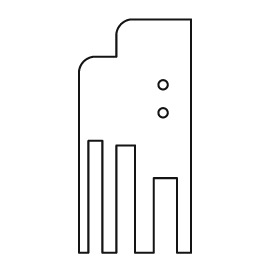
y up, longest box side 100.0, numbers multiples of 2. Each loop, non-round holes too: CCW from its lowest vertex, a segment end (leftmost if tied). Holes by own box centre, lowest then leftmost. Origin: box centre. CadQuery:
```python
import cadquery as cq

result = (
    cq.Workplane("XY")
    .moveTo(-24.0, -50.0)
    .lineTo(-20.0, -50.0)
    .lineTo(-20.0, -2.0)
    .lineTo(-14.0, -2.0)
    .lineTo(-14.0, -50.0)
    .lineTo(-8.0, -50.0)
    .lineTo(-8.0, -4.0)
    .lineTo(0.0, -4.0)
    .lineTo(0.0, -50.0)
    .lineTo(8.0, -50.0)
    .lineTo(8.0, -18.0)
    .lineTo(18.0, -18.0)
    .lineTo(18.0, -50.0)
    .lineTo(24.0, -50.0)
    .lineTo(24.0, 50.0)
    .lineTo(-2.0, 50.0)
    .threePointArc((-6.0, 48.0), (-8.0, 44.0))
    .lineTo(-8.0, 34.0)
    .lineTo(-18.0, 34.0)
    .threePointArc((-22.0, 32.0), (-24.0, 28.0))
    .close()
    .moveTo(12.0, 10.0)
    .circle(2.0)
    .moveTo(12.0, 22.0)
    .circle(2.0)
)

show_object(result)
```